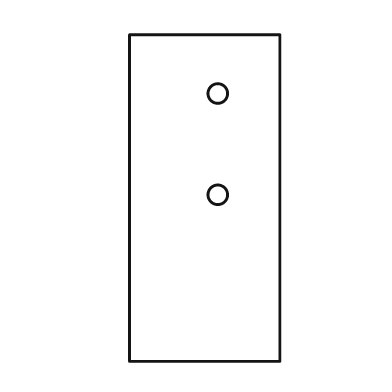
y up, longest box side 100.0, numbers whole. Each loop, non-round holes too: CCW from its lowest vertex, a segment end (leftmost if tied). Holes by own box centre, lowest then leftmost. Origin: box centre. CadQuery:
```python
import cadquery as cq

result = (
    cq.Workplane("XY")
    .moveTo(-23.0, -50.0)
    .lineTo(23.0, -50.0)
    .lineTo(23.0, 50.0)
    .lineTo(-23.0, 50.0)
    .close()
    .moveTo(4.0, 1.0)
    .circle(3.0)
    .moveTo(4.0, 32.0)
    .circle(3.0)
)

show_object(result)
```